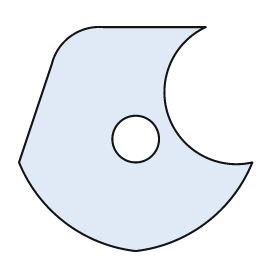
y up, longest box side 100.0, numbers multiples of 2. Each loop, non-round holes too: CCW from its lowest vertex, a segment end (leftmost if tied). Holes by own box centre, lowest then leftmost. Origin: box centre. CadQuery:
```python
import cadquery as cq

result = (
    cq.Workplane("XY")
    .moveTo(0.0, -48.0)
    .threePointArc((30.0, -36.0), (50.0, -10.0))
    .threePointArc((14.0, 10.0), (30.0, 48.0))
    .lineTo(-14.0, 48.0)
    .threePointArc((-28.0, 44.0), (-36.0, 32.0))
    .lineTo(-50.0, -10.0)
    .threePointArc((-30.0, -36.0), (0.0, -48.0))
    .close()
    .moveTo(0.0, 0.0)
    .circle(10.0)
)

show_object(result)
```